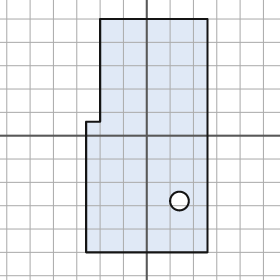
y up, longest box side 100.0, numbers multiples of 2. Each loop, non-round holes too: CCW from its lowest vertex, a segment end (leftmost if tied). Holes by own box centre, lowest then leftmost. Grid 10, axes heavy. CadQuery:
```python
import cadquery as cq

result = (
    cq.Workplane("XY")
    .moveTo(-26.0, -50.0)
    .lineTo(26.0, -50.0)
    .lineTo(26.0, 50.0)
    .lineTo(-20.0, 50.0)
    .lineTo(-20.0, 6.0)
    .lineTo(-26.0, 6.0)
    .close()
    .moveTo(14.0, -28.0)
    .circle(4.0)
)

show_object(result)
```